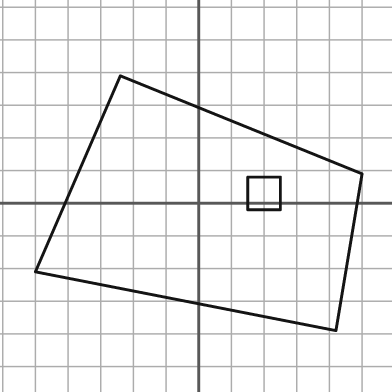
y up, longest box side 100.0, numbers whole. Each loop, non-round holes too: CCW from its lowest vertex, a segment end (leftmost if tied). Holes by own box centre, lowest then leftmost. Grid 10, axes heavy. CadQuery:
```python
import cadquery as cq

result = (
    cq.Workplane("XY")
    .moveTo(42.0, -39.0)
    .lineTo(50.0, 9.0)
    .lineTo(-24.0, 39.0)
    .lineTo(-50.0, -21.0)
    .close()
    .moveTo(15.0, -2.0)
    .lineTo(25.0, -2.0)
    .lineTo(25.0, 8.0)
    .lineTo(15.0, 8.0)
    .close()
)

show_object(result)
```